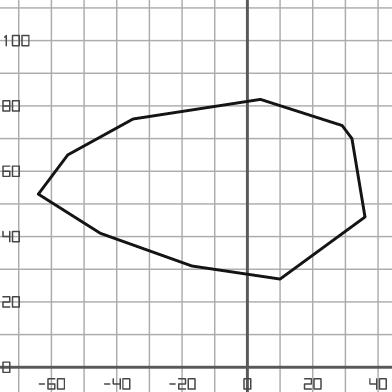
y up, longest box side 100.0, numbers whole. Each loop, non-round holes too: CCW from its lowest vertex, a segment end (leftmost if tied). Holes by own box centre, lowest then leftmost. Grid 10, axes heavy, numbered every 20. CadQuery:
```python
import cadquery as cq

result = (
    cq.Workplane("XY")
    .moveTo(10.0, 27.0)
    .lineTo(36.0, 46.0)
    .lineTo(32.0, 70.0)
    .lineTo(29.0, 74.0)
    .lineTo(4.0, 82.0)
    .lineTo(-35.0, 76.0)
    .lineTo(-55.0, 65.0)
    .lineTo(-64.0, 53.0)
    .lineTo(-45.0, 41.0)
    .lineTo(-17.0, 31.0)
    .close()
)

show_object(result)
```